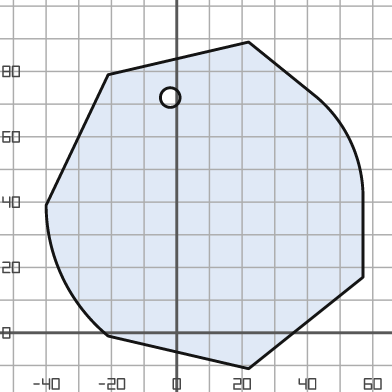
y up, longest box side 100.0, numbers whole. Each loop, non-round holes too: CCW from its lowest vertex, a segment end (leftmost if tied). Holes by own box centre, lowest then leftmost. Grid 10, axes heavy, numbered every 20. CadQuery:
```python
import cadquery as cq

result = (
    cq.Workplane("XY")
    .moveTo(22.0, -11.0)
    .lineTo(57.0, 17.0)
    .lineTo(57.0, 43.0)
    .threePointArc((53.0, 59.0), (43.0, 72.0))
    .lineTo(22.0, 89.0)
    .lineTo(-21.0, 79.0)
    .lineTo(-40.0, 39.0)
    .threePointArc((-35.0, 17.0), (-21.0, -1.0))
    .close()
    .moveTo(-2.0, 72.0)
    .circle(3.0)
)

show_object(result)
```